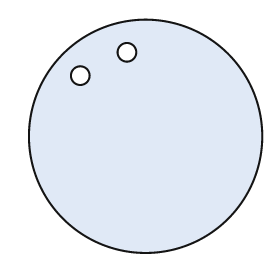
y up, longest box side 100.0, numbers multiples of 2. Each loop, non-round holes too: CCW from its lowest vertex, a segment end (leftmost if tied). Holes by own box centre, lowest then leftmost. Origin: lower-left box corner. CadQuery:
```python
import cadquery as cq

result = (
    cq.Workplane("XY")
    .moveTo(50.0, 50.0)
    .circle(50.0)
    .moveTo(22.0, 76.0)
    .circle(4.0)
    .moveTo(42.0, 86.0)
    .circle(4.0)
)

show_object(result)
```